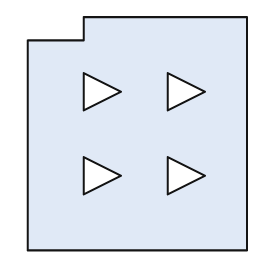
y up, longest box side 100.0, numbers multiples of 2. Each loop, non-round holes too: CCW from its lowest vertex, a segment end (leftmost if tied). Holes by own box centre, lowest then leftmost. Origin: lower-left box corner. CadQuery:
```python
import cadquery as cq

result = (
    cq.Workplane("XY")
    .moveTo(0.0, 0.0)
    .lineTo(94.0, 0.0)
    .lineTo(94.0, 100.0)
    .lineTo(24.0, 100.0)
    .lineTo(24.0, 90.0)
    .lineTo(0.0, 90.0)
    .close()
    .moveTo(24.0, 24.0)
    .lineTo(40.0, 32.0)
    .lineTo(24.0, 40.0)
    .close()
    .moveTo(60.0, 24.0)
    .lineTo(76.0, 32.0)
    .lineTo(60.0, 40.0)
    .close()
    .moveTo(24.0, 60.0)
    .lineTo(40.0, 68.0)
    .lineTo(24.0, 76.0)
    .close()
    .moveTo(60.0, 60.0)
    .lineTo(76.0, 68.0)
    .lineTo(60.0, 76.0)
    .close()
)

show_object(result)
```